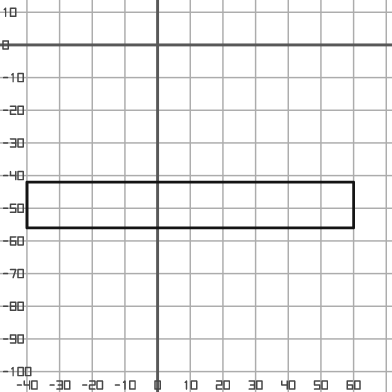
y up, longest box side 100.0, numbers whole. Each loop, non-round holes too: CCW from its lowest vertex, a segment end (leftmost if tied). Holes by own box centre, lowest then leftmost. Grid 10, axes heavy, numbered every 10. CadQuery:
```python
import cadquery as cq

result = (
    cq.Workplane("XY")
    .moveTo(-40.0, -56.0)
    .lineTo(60.0, -56.0)
    .lineTo(60.0, -42.0)
    .lineTo(-40.0, -42.0)
    .close()
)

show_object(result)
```